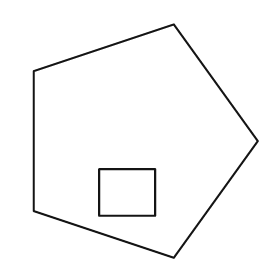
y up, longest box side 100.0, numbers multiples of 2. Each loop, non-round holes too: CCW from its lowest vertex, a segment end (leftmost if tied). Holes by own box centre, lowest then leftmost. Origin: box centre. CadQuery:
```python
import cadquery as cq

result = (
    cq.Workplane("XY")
    .moveTo(12.0, -50.0)
    .lineTo(48.0, 0.0)
    .lineTo(12.0, 50.0)
    .lineTo(-48.0, 30.0)
    .lineTo(-48.0, -30.0)
    .close()
    .moveTo(-20.0, -32.0)
    .lineTo(4.0, -32.0)
    .lineTo(4.0, -12.0)
    .lineTo(-20.0, -12.0)
    .close()
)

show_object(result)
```